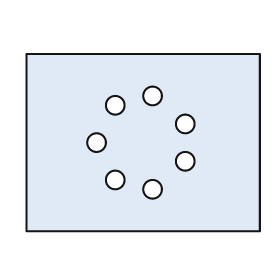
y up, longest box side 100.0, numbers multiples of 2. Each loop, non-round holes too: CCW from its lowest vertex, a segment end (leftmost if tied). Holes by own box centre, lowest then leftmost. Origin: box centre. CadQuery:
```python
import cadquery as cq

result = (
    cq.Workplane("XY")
    .moveTo(-50.0, -38.0)
    .lineTo(50.0, -38.0)
    .lineTo(50.0, 38.0)
    .lineTo(-50.0, 38.0)
    .close()
    .moveTo(4.0, -20.0)
    .circle(4.0)
    .moveTo(-12.0, -16.0)
    .circle(4.0)
    .moveTo(18.0, -8.0)
    .circle(4.0)
    .moveTo(-20.0, 0.0)
    .circle(4.0)
    .moveTo(18.0, 8.0)
    .circle(4.0)
    .moveTo(-12.0, 16.0)
    .circle(4.0)
    .moveTo(4.0, 20.0)
    .circle(4.0)
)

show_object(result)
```